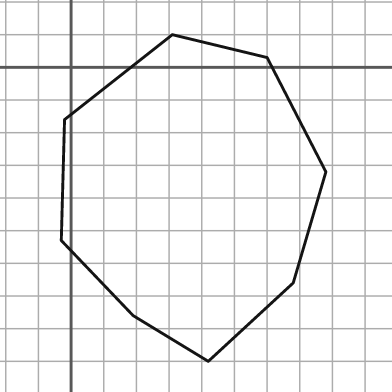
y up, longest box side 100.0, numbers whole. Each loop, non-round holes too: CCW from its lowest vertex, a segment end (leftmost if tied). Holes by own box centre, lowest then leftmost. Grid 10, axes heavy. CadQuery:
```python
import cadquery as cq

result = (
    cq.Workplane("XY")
    .moveTo(42.0, -90.0)
    .lineTo(68.0, -66.0)
    .lineTo(78.0, -32.0)
    .lineTo(60.0, 3.0)
    .lineTo(31.0, 10.0)
    .lineTo(-2.0, -16.0)
    .lineTo(-3.0, -53.0)
    .lineTo(19.0, -76.0)
    .close()
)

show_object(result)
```